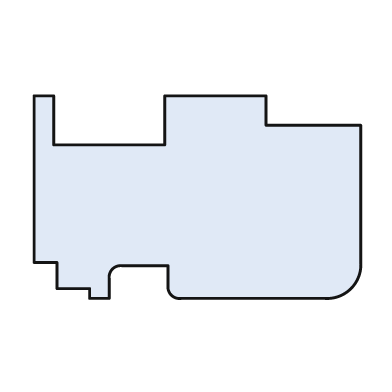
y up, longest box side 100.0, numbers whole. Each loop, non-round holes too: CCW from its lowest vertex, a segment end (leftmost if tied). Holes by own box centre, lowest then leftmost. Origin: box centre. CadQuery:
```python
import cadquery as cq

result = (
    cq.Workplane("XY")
    .moveTo(-33.0, -31.0)
    .lineTo(-27.0, -31.0)
    .lineTo(-27.0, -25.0)
    .threePointArc((-26.0, -22.0), (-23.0, -21.0))
    .lineTo(-9.0, -21.0)
    .lineTo(-9.0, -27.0)
    .threePointArc((-8.0, -30.0), (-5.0, -31.0))
    .lineTo(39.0, -31.0)
    .threePointArc((47.0, -28.0), (50.0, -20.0))
    .lineTo(50.0, 22.0)
    .lineTo(21.0, 22.0)
    .lineTo(21.0, 31.0)
    .lineTo(-10.0, 31.0)
    .lineTo(-10.0, 16.0)
    .lineTo(-44.0, 16.0)
    .lineTo(-44.0, 31.0)
    .lineTo(-50.0, 31.0)
    .lineTo(-50.0, -20.0)
    .lineTo(-43.0, -20.0)
    .lineTo(-43.0, -28.0)
    .lineTo(-33.0, -28.0)
    .close()
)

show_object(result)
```